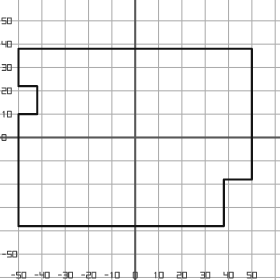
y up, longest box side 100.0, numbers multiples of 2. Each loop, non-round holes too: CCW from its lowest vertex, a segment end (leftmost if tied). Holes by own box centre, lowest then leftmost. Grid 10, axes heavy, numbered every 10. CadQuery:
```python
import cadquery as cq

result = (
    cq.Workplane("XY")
    .moveTo(-50.0, -38.0)
    .lineTo(38.0, -38.0)
    .lineTo(38.0, -18.0)
    .lineTo(50.0, -18.0)
    .lineTo(50.0, 38.0)
    .lineTo(-50.0, 38.0)
    .lineTo(-50.0, 22.0)
    .lineTo(-42.0, 22.0)
    .lineTo(-42.0, 10.0)
    .lineTo(-50.0, 10.0)
    .close()
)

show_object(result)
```